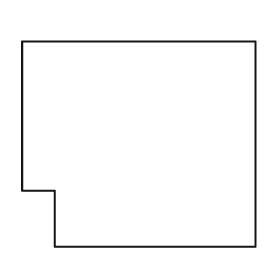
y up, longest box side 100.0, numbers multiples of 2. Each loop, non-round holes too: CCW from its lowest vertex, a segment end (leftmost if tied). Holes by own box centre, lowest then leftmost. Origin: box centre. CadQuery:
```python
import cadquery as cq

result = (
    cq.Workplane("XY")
    .moveTo(-36.0, -44.0)
    .lineTo(50.0, -44.0)
    .lineTo(50.0, 44.0)
    .lineTo(-50.0, 44.0)
    .lineTo(-50.0, -20.0)
    .lineTo(-36.0, -20.0)
    .close()
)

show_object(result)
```